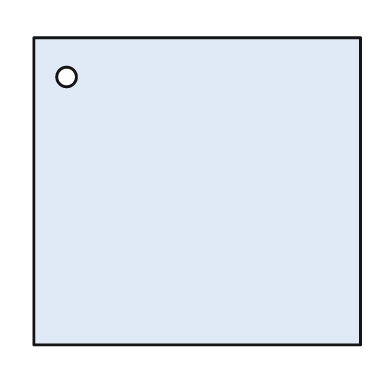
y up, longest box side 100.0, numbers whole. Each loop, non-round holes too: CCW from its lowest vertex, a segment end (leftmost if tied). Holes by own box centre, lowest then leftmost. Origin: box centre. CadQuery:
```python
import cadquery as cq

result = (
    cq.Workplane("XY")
    .moveTo(-50.0, -47.0)
    .lineTo(50.0, -47.0)
    .lineTo(50.0, 47.0)
    .lineTo(-50.0, 47.0)
    .close()
    .moveTo(-40.0, 35.0)
    .circle(3.0)
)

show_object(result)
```